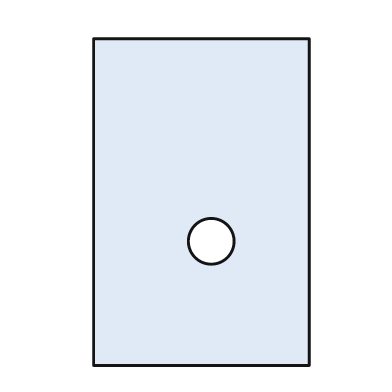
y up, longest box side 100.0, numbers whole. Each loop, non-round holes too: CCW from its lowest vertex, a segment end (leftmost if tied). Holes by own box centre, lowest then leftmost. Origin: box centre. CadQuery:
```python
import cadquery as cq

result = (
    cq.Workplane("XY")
    .moveTo(-33.0, -50.0)
    .lineTo(33.0, -50.0)
    .lineTo(33.0, 50.0)
    .lineTo(-33.0, 50.0)
    .close()
    .moveTo(3.0, -12.0)
    .circle(7.0)
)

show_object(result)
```